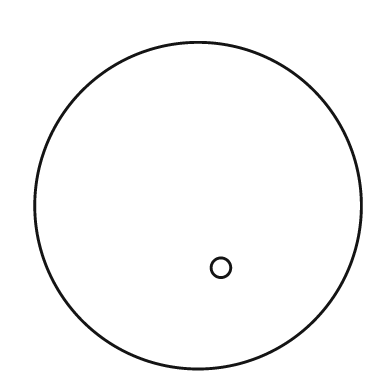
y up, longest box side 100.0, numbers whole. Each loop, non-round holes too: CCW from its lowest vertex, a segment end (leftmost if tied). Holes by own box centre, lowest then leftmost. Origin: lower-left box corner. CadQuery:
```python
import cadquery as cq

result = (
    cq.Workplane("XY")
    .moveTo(50.0, 50.0)
    .circle(50.0)
    .moveTo(57.0, 31.0)
    .circle(3.0)
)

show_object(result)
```